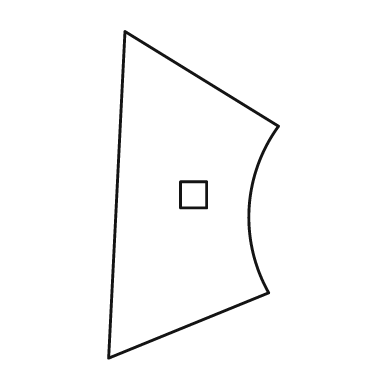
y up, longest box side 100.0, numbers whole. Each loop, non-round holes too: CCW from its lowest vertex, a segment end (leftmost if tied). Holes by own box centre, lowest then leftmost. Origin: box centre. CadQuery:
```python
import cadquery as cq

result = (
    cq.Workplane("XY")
    .moveTo(-26.0, -50.0)
    .lineTo(23.0, -30.0)
    .threePointArc((17.0, -4.0), (26.0, 21.0))
    .lineTo(-21.0, 50.0)
    .close()
    .moveTo(-4.0, -4.0)
    .lineTo(4.0, -4.0)
    .lineTo(4.0, 4.0)
    .lineTo(-4.0, 4.0)
    .close()
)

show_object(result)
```